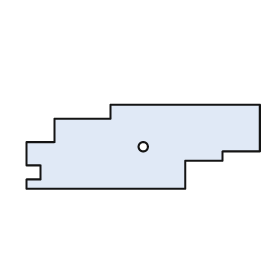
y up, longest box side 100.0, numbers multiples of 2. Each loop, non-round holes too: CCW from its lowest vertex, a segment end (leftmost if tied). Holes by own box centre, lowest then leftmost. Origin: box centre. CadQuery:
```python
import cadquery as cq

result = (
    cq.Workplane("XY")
    .moveTo(-50.0, -18.0)
    .lineTo(18.0, -18.0)
    .lineTo(18.0, -6.0)
    .lineTo(34.0, -6.0)
    .lineTo(34.0, -2.0)
    .lineTo(50.0, -2.0)
    .lineTo(50.0, 18.0)
    .lineTo(-14.0, 18.0)
    .lineTo(-14.0, 12.0)
    .lineTo(-38.0, 12.0)
    .lineTo(-38.0, 2.0)
    .lineTo(-50.0, 2.0)
    .lineTo(-50.0, -8.0)
    .lineTo(-44.0, -8.0)
    .lineTo(-44.0, -14.0)
    .lineTo(-50.0, -14.0)
    .close()
    .moveTo(0.0, 0.0)
    .circle(2.0)
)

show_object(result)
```